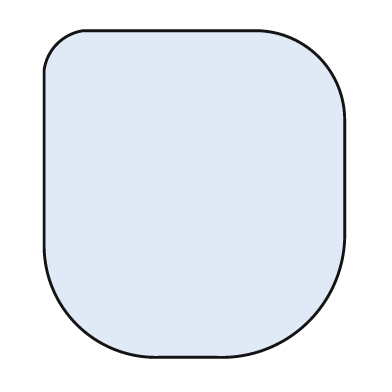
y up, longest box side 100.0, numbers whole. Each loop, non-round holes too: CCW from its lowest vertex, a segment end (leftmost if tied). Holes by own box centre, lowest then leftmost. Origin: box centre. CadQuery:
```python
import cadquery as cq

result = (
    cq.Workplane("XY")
    .moveTo(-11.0, -50.0)
    .lineTo(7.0, -50.0)
    .threePointArc((35.0, -39.0), (46.0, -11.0))
    .lineTo(46.0, 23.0)
    .threePointArc((38.0, 42.0), (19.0, 50.0))
    .lineTo(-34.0, 50.0)
    .threePointArc((-42.0, 46.0), (-46.0, 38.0))
    .lineTo(-46.0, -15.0)
    .threePointArc((-36.0, -40.0), (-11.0, -50.0))
    .close()
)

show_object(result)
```